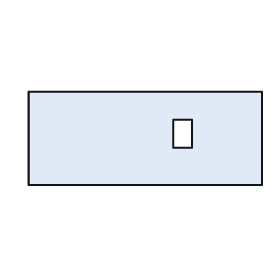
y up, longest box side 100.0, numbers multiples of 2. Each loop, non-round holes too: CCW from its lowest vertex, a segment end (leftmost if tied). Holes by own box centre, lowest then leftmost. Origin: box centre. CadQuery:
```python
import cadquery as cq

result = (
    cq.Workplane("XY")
    .moveTo(-50.0, -20.0)
    .lineTo(50.0, -20.0)
    .lineTo(50.0, 20.0)
    .lineTo(-50.0, 20.0)
    .close()
    .moveTo(12.0, -4.0)
    .lineTo(20.0, -4.0)
    .lineTo(20.0, 8.0)
    .lineTo(12.0, 8.0)
    .close()
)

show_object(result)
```